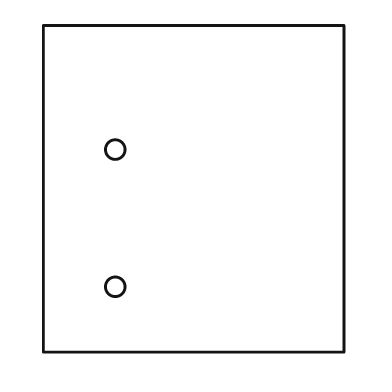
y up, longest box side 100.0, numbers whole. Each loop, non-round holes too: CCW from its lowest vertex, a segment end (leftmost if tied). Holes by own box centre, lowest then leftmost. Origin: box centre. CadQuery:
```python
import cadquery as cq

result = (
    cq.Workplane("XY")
    .moveTo(-46.0, -50.0)
    .lineTo(46.0, -50.0)
    .lineTo(46.0, 50.0)
    .lineTo(-46.0, 50.0)
    .close()
    .moveTo(-24.0, -30.0)
    .circle(3.0)
    .moveTo(-24.0, 12.0)
    .circle(3.0)
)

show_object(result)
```